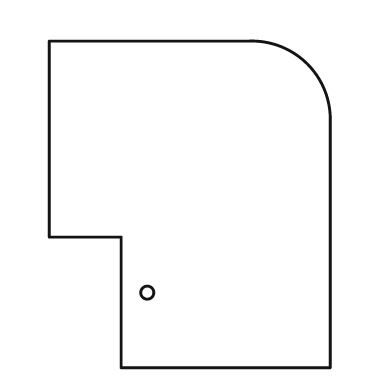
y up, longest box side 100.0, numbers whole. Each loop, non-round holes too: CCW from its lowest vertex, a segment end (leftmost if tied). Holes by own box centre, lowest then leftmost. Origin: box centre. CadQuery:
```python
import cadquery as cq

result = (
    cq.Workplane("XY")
    .moveTo(-21.0, -50.0)
    .lineTo(43.0, -50.0)
    .lineTo(43.0, 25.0)
    .threePointArc((36.0, 43.0), (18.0, 50.0))
    .lineTo(-43.0, 50.0)
    .lineTo(-43.0, -10.0)
    .lineTo(-21.0, -10.0)
    .close()
    .moveTo(-13.0, -27.0)
    .circle(2.0)
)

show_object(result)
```